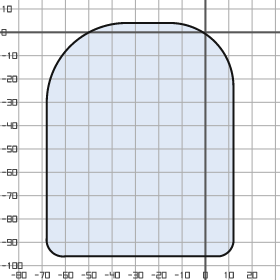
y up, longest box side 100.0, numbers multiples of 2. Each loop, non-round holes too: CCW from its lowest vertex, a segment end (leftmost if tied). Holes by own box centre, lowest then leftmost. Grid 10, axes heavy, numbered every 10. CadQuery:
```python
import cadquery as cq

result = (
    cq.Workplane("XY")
    .moveTo(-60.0, -96.0)
    .lineTo(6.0, -96.0)
    .threePointArc((10.0, -94.0), (12.0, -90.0))
    .lineTo(12.0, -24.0)
    .threePointArc((4.0, -4.0), (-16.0, 4.0))
    .lineTo(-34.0, 4.0)
    .threePointArc((-58.0, -6.0), (-68.0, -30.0))
    .lineTo(-68.0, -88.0)
    .threePointArc((-66.0, -94.0), (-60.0, -96.0))
    .close()
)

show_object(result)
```